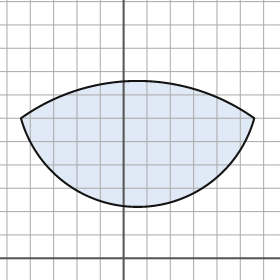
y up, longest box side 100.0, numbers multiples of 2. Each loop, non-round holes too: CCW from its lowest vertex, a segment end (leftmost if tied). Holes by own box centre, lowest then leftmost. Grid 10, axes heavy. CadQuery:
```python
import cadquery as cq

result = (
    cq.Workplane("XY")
    .moveTo(-44.0, 60.0)
    .threePointArc((6.0, 22.0), (56.0, 60.0))
    .threePointArc((6.0, 76.0), (-44.0, 60.0))
    .close()
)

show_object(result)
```